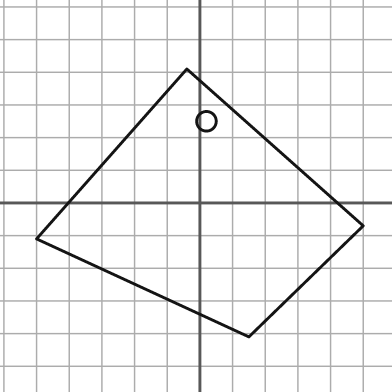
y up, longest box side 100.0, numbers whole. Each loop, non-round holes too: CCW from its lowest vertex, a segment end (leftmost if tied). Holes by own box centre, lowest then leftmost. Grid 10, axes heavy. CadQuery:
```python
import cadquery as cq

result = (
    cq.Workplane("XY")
    .moveTo(15.0, -41.0)
    .lineTo(50.0, -7.0)
    .lineTo(-4.0, 41.0)
    .lineTo(-50.0, -11.0)
    .close()
    .moveTo(2.0, 25.0)
    .circle(3.0)
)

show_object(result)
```